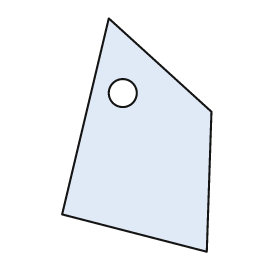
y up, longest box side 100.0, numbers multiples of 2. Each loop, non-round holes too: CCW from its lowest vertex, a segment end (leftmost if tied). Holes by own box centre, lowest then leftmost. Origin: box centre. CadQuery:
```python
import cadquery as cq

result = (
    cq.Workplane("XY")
    .moveTo(30.0, -50.0)
    .lineTo(32.0, 10.0)
    .lineTo(-12.0, 50.0)
    .lineTo(-32.0, -34.0)
    .close()
    .moveTo(-6.0, 18.0)
    .circle(6.0)
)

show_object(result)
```